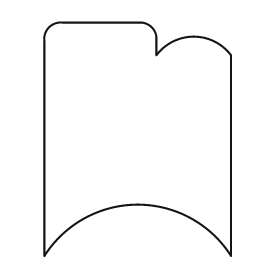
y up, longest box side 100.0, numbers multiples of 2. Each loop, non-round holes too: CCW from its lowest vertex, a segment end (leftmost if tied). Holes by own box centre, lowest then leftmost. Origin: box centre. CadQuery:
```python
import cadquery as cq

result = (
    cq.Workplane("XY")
    .moveTo(-40.0, -50.0)
    .threePointArc((0.0, -28.0), (40.0, -50.0))
    .lineTo(40.0, 36.0)
    .threePointArc((24.0, 44.0), (8.0, 36.0))
    .lineTo(8.0, 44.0)
    .threePointArc((6.0, 48.0), (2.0, 50.0))
    .lineTo(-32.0, 50.0)
    .threePointArc((-38.0, 48.0), (-40.0, 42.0))
    .close()
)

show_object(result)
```